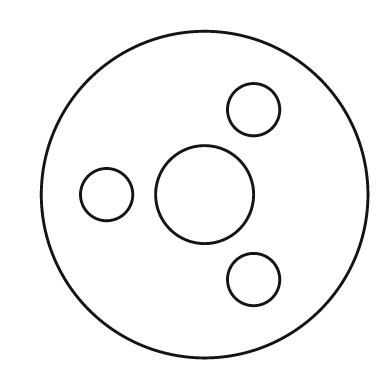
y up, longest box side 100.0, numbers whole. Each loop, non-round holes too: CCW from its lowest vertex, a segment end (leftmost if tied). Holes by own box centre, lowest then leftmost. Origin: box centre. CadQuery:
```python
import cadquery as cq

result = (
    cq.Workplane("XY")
    .moveTo(0.0, 0.0)
    .circle(50.0)
    .moveTo(15.0, -26.0)
    .circle(8.0)
    .moveTo(-30.0, 0.0)
    .circle(8.0)
    .moveTo(0.0, 0.0)
    .circle(15.0)
    .moveTo(15.0, 26.0)
    .circle(8.0)
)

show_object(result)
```